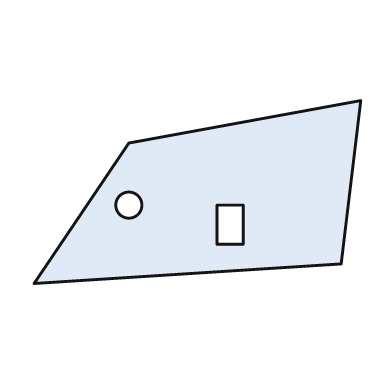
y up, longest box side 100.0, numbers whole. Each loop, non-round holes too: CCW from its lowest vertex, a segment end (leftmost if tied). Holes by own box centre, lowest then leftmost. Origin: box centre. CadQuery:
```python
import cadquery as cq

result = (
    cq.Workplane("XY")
    .moveTo(-50.0, -28.0)
    .lineTo(44.0, -22.0)
    .lineTo(50.0, 28.0)
    .lineTo(-21.0, 15.0)
    .close()
    .moveTo(6.0, -16.0)
    .lineTo(14.0, -16.0)
    .lineTo(14.0, -4.0)
    .lineTo(6.0, -4.0)
    .close()
    .moveTo(-21.0, -4.0)
    .circle(4.0)
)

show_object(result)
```